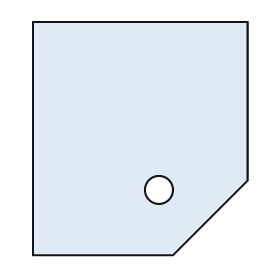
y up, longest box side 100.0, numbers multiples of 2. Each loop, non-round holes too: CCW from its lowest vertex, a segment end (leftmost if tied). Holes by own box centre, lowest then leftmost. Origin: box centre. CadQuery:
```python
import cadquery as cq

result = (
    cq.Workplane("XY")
    .moveTo(-46.0, -50.0)
    .lineTo(14.0, -50.0)
    .lineTo(46.0, -18.0)
    .lineTo(46.0, 50.0)
    .lineTo(-46.0, 50.0)
    .close()
    .moveTo(8.0, -22.0)
    .circle(6.0)
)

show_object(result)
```